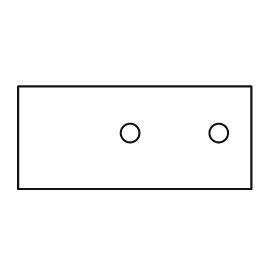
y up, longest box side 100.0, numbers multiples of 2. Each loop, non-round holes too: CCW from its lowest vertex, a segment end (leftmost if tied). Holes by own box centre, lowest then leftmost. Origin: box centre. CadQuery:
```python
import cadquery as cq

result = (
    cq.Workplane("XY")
    .moveTo(-50.0, -22.0)
    .lineTo(50.0, -22.0)
    .lineTo(50.0, 22.0)
    .lineTo(-50.0, 22.0)
    .close()
    .moveTo(-2.0, 2.0)
    .circle(4.0)
    .moveTo(36.0, 2.0)
    .circle(4.0)
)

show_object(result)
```